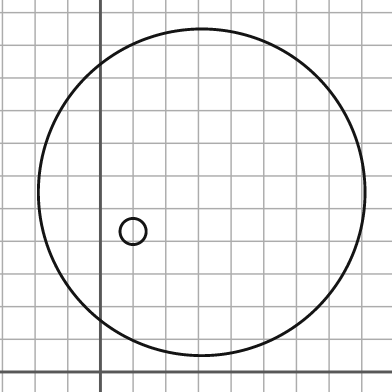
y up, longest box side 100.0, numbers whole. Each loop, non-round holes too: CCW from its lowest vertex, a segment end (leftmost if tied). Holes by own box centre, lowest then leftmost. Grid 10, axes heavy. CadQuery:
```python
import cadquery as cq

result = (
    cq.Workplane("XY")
    .moveTo(31.0, 55.0)
    .circle(50.0)
    .moveTo(10.0, 43.0)
    .circle(4.0)
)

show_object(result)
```